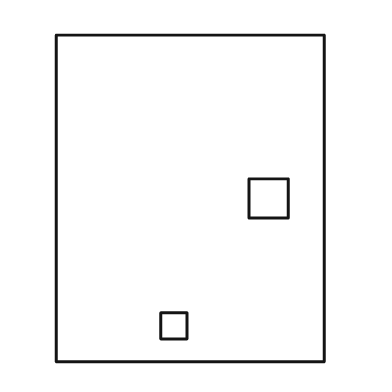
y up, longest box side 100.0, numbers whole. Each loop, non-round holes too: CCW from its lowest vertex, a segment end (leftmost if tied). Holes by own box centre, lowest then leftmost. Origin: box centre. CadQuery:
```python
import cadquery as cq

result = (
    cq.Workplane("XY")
    .moveTo(-41.0, -50.0)
    .lineTo(41.0, -50.0)
    .lineTo(41.0, 50.0)
    .lineTo(-41.0, 50.0)
    .close()
    .moveTo(-9.0, -43.0)
    .lineTo(-1.0, -43.0)
    .lineTo(-1.0, -35.0)
    .lineTo(-9.0, -35.0)
    .close()
    .moveTo(18.0, -6.0)
    .lineTo(30.0, -6.0)
    .lineTo(30.0, 6.0)
    .lineTo(18.0, 6.0)
    .close()
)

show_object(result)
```